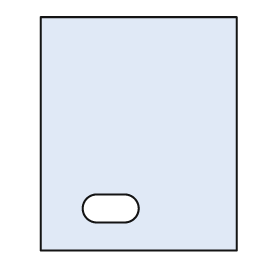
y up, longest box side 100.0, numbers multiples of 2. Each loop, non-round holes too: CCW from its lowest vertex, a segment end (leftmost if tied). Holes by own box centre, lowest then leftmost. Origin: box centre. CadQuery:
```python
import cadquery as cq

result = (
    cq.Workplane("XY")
    .moveTo(-42.0, -50.0)
    .lineTo(42.0, -50.0)
    .lineTo(42.0, 50.0)
    .lineTo(-42.0, 50.0)
    .close()
    .moveTo(-18.0, -38.0)
    .lineTo(-6.0, -38.0)
    .threePointArc((0.0, -32.0), (-6.0, -26.0))
    .lineTo(-18.0, -26.0)
    .threePointArc((-24.0, -32.0), (-18.0, -38.0))
    .close()
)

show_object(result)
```